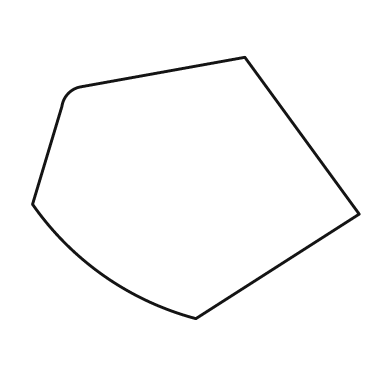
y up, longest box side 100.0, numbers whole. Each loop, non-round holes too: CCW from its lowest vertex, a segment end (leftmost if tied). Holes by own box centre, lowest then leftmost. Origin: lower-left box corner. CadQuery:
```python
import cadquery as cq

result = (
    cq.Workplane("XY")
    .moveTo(50.0, 0.0)
    .lineTo(100.0, 32.0)
    .lineTo(65.0, 80.0)
    .lineTo(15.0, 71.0)
    .threePointArc((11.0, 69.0), (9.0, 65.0))
    .lineTo(0.0, 35.0)
    .threePointArc((22.0, 13.0), (50.0, 0.0))
    .close()
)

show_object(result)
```